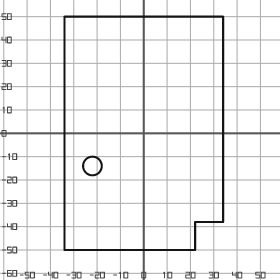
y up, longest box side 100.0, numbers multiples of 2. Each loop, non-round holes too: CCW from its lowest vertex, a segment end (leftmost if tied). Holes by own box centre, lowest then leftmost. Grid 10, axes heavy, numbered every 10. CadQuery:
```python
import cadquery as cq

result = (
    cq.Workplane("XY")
    .moveTo(-34.0, -50.0)
    .lineTo(22.0, -50.0)
    .lineTo(22.0, -38.0)
    .lineTo(34.0, -38.0)
    .lineTo(34.0, 50.0)
    .lineTo(-34.0, 50.0)
    .close()
    .moveTo(-22.0, -14.0)
    .circle(4.0)
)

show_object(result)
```